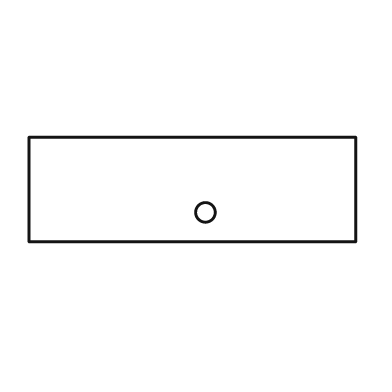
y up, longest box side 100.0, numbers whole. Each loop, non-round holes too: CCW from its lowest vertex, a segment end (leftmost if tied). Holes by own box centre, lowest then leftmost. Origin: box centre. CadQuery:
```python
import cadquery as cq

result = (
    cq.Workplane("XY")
    .moveTo(-50.0, -16.0)
    .lineTo(50.0, -16.0)
    .lineTo(50.0, 16.0)
    .lineTo(-50.0, 16.0)
    .close()
    .moveTo(4.0, -7.0)
    .circle(3.0)
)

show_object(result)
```